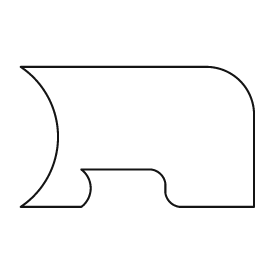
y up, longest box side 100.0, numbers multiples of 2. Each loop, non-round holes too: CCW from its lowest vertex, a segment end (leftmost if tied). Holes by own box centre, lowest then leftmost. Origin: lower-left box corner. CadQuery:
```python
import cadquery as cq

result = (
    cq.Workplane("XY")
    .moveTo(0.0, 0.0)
    .lineTo(26.0, 0.0)
    .threePointArc((30.0, 8.0), (26.0, 16.0))
    .lineTo(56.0, 16.0)
    .threePointArc((60.0, 14.0), (62.0, 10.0))
    .lineTo(62.0, 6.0)
    .threePointArc((64.0, 2.0), (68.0, 0.0))
    .lineTo(100.0, 0.0)
    .lineTo(100.0, 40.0)
    .threePointArc((94.0, 54.0), (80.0, 60.0))
    .lineTo(0.0, 60.0)
    .threePointArc((16.0, 30.0), (0.0, 0.0))
    .close()
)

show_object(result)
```